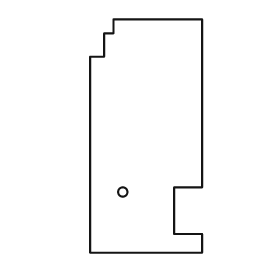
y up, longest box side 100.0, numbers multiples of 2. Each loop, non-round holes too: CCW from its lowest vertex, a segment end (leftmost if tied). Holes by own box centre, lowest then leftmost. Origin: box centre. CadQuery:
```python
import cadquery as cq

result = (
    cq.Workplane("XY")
    .moveTo(-24.0, -50.0)
    .lineTo(24.0, -50.0)
    .lineTo(24.0, -42.0)
    .lineTo(12.0, -42.0)
    .lineTo(12.0, -22.0)
    .lineTo(24.0, -22.0)
    .lineTo(24.0, 50.0)
    .lineTo(-14.0, 50.0)
    .lineTo(-14.0, 44.0)
    .lineTo(-18.0, 44.0)
    .lineTo(-18.0, 34.0)
    .lineTo(-24.0, 34.0)
    .close()
    .moveTo(-10.0, -24.0)
    .circle(2.0)
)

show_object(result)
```